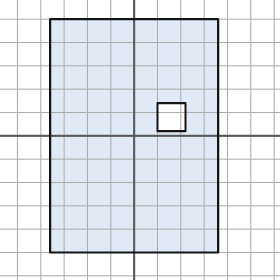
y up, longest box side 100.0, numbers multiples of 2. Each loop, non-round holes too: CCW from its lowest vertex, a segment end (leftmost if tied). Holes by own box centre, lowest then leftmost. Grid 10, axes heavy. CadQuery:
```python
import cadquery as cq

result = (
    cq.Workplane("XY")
    .moveTo(-36.0, -50.0)
    .lineTo(36.0, -50.0)
    .lineTo(36.0, 50.0)
    .lineTo(-36.0, 50.0)
    .close()
    .moveTo(10.0, 2.0)
    .lineTo(22.0, 2.0)
    .lineTo(22.0, 14.0)
    .lineTo(10.0, 14.0)
    .close()
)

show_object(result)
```